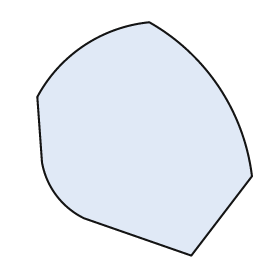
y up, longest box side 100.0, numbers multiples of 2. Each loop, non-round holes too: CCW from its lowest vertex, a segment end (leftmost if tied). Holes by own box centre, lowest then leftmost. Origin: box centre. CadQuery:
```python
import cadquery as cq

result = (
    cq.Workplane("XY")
    .moveTo(20.0, -50.0)
    .lineTo(46.0, -16.0)
    .threePointArc((32.0, 22.0), (2.0, 50.0))
    .threePointArc((-26.0, 40.0), (-46.0, 18.0))
    .lineTo(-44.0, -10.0)
    .threePointArc((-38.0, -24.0), (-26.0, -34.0))
    .close()
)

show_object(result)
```